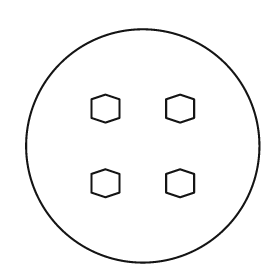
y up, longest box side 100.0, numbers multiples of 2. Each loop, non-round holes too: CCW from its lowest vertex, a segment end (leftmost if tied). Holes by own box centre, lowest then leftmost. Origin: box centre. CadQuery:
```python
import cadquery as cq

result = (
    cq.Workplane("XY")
    .moveTo(0.0, 0.0)
    .circle(50.0)
    .moveTo(-16.0, -22.0)
    .lineTo(-10.0, -20.0)
    .lineTo(-10.0, -12.0)
    .lineTo(-16.0, -10.0)
    .lineTo(-22.0, -12.0)
    .lineTo(-22.0, -20.0)
    .close()
    .moveTo(16.0, -22.0)
    .lineTo(22.0, -20.0)
    .lineTo(22.0, -12.0)
    .lineTo(16.0, -10.0)
    .lineTo(10.0, -12.0)
    .lineTo(10.0, -20.0)
    .close()
    .moveTo(-16.0, 10.0)
    .lineTo(-10.0, 12.0)
    .lineTo(-10.0, 20.0)
    .lineTo(-16.0, 22.0)
    .lineTo(-22.0, 20.0)
    .lineTo(-22.0, 12.0)
    .close()
    .moveTo(16.0, 10.0)
    .lineTo(22.0, 12.0)
    .lineTo(22.0, 20.0)
    .lineTo(16.0, 22.0)
    .lineTo(10.0, 20.0)
    .lineTo(10.0, 12.0)
    .close()
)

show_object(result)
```